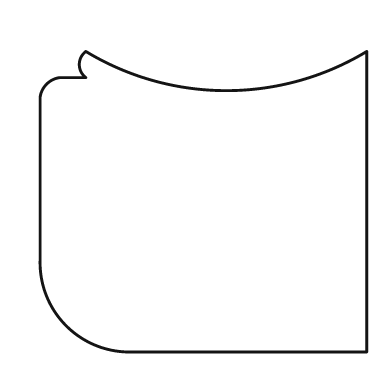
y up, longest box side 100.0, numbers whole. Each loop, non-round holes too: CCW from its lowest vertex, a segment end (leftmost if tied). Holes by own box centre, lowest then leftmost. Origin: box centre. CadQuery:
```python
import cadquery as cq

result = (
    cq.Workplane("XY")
    .moveTo(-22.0, -46.0)
    .lineTo(50.0, -46.0)
    .lineTo(50.0, 46.0)
    .threePointArc((7.0, 34.0), (-36.0, 46.0))
    .threePointArc((-38.0, 42.0), (-36.0, 38.0))
    .lineTo(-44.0, 38.0)
    .threePointArc((-48.0, 36.0), (-50.0, 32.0))
    .lineTo(-50.0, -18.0)
    .threePointArc((-42.0, -38.0), (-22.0, -46.0))
    .close()
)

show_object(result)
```